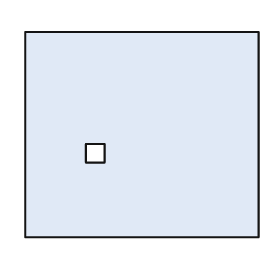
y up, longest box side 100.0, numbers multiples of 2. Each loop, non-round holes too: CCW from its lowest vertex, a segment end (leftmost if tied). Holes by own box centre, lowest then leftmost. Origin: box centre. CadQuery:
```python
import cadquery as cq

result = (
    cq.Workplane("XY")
    .moveTo(-50.0, -44.0)
    .lineTo(50.0, -44.0)
    .lineTo(50.0, 44.0)
    .lineTo(-50.0, 44.0)
    .close()
    .moveTo(-24.0, -12.0)
    .lineTo(-16.0, -12.0)
    .lineTo(-16.0, -4.0)
    .lineTo(-24.0, -4.0)
    .close()
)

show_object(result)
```